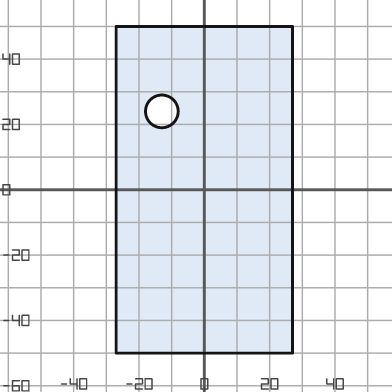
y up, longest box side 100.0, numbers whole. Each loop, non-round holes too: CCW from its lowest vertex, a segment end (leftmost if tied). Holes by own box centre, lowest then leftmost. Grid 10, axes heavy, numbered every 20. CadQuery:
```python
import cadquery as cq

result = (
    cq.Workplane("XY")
    .moveTo(-27.0, -50.0)
    .lineTo(27.0, -50.0)
    .lineTo(27.0, 50.0)
    .lineTo(-27.0, 50.0)
    .close()
    .moveTo(-13.0, 24.0)
    .circle(5.0)
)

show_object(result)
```